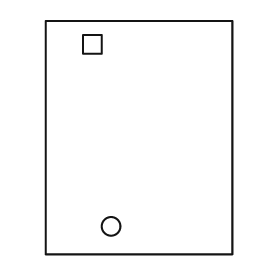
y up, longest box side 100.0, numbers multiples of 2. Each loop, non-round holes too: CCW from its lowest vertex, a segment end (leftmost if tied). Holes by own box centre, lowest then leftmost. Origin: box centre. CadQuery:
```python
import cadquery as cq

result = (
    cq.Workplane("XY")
    .moveTo(-40.0, -50.0)
    .lineTo(40.0, -50.0)
    .lineTo(40.0, 50.0)
    .lineTo(-40.0, 50.0)
    .close()
    .moveTo(-12.0, -38.0)
    .circle(4.0)
    .moveTo(-24.0, 36.0)
    .lineTo(-16.0, 36.0)
    .lineTo(-16.0, 44.0)
    .lineTo(-24.0, 44.0)
    .close()
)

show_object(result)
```